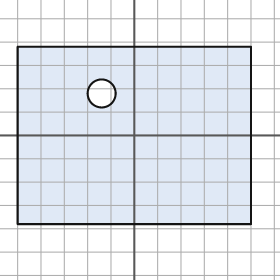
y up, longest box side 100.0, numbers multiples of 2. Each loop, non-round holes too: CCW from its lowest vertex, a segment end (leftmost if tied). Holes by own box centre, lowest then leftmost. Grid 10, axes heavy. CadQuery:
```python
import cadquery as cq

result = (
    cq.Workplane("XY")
    .moveTo(-50.0, -38.0)
    .lineTo(50.0, -38.0)
    .lineTo(50.0, 38.0)
    .lineTo(-50.0, 38.0)
    .close()
    .moveTo(-14.0, 18.0)
    .circle(6.0)
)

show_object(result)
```